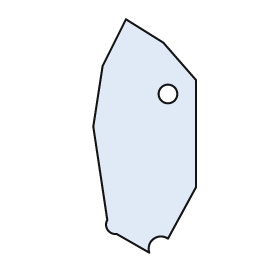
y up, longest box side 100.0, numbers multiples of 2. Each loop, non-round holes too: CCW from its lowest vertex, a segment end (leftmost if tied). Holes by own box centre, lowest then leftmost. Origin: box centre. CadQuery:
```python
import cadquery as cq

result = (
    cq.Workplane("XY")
    .moveTo(2.0, -50.0)
    .threePointArc((4.0, -44.0), (10.0, -44.0))
    .lineTo(22.0, -22.0)
    .lineTo(22.0, 24.0)
    .lineTo(8.0, 40.0)
    .lineTo(-8.0, 50.0)
    .lineTo(-18.0, 30.0)
    .lineTo(-22.0, 4.0)
    .lineTo(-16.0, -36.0)
    .threePointArc((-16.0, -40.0), (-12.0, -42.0))
    .close()
    .moveTo(10.0, 18.0)
    .circle(4.0)
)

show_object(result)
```